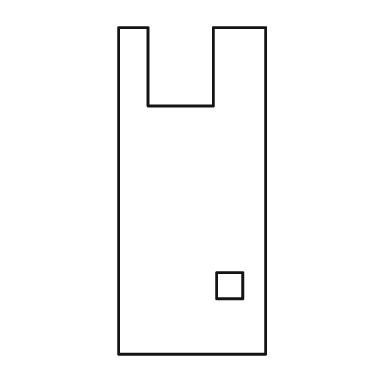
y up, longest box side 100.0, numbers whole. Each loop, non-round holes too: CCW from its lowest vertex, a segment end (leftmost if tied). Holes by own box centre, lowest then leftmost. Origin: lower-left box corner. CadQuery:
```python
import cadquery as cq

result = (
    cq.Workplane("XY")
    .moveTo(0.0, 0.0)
    .lineTo(45.0, 0.0)
    .lineTo(45.0, 100.0)
    .lineTo(29.0, 100.0)
    .lineTo(29.0, 76.0)
    .lineTo(9.0, 76.0)
    .lineTo(9.0, 100.0)
    .lineTo(0.0, 100.0)
    .close()
    .moveTo(30.0, 17.0)
    .lineTo(38.0, 17.0)
    .lineTo(38.0, 25.0)
    .lineTo(30.0, 25.0)
    .close()
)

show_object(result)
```